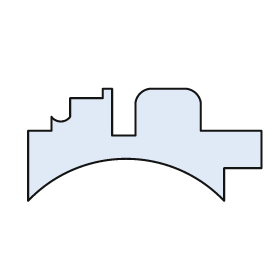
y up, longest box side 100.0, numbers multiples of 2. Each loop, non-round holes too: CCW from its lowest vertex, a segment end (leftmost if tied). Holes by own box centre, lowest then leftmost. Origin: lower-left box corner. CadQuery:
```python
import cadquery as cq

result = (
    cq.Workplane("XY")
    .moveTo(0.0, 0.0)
    .threePointArc((42.0, 18.0), (84.0, 0.0))
    .lineTo(84.0, 14.0)
    .lineTo(100.0, 14.0)
    .lineTo(100.0, 30.0)
    .lineTo(74.0, 30.0)
    .lineTo(74.0, 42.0)
    .threePointArc((72.0, 46.0), (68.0, 48.0))
    .lineTo(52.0, 48.0)
    .threePointArc((48.0, 46.0), (46.0, 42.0))
    .lineTo(46.0, 28.0)
    .lineTo(36.0, 28.0)
    .lineTo(36.0, 48.0)
    .lineTo(32.0, 48.0)
    .lineTo(32.0, 44.0)
    .lineTo(18.0, 44.0)
    .lineTo(18.0, 36.0)
    .threePointArc((14.0, 34.0), (10.0, 36.0))
    .lineTo(10.0, 30.0)
    .lineTo(0.0, 30.0)
    .close()
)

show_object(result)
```